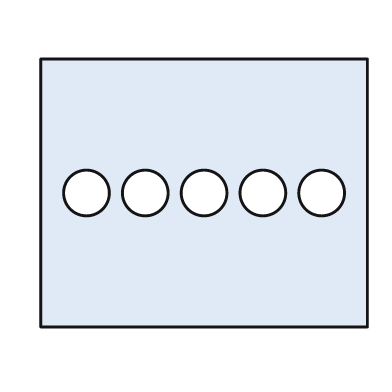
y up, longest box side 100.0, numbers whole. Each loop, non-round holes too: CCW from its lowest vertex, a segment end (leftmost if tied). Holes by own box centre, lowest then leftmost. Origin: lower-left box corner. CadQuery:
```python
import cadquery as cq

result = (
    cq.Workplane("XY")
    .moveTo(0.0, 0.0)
    .lineTo(100.0, 0.0)
    .lineTo(100.0, 82.0)
    .lineTo(0.0, 82.0)
    .close()
    .moveTo(14.0, 41.0)
    .circle(7.0)
    .moveTo(32.0, 41.0)
    .circle(7.0)
    .moveTo(50.0, 41.0)
    .circle(7.0)
    .moveTo(68.0, 41.0)
    .circle(7.0)
    .moveTo(86.0, 41.0)
    .circle(7.0)
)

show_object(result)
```